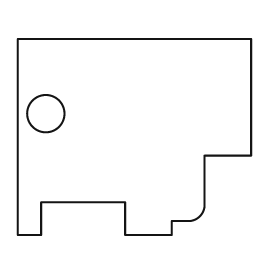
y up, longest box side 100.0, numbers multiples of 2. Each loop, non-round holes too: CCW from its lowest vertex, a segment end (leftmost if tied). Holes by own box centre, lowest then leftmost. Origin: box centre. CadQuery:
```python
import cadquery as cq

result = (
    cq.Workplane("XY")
    .moveTo(-50.0, -42.0)
    .lineTo(-40.0, -42.0)
    .lineTo(-40.0, -28.0)
    .lineTo(-4.0, -28.0)
    .lineTo(-4.0, -42.0)
    .lineTo(16.0, -42.0)
    .lineTo(16.0, -36.0)
    .lineTo(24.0, -36.0)
    .threePointArc((28.0, -34.0), (30.0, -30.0))
    .lineTo(30.0, -8.0)
    .lineTo(50.0, -8.0)
    .lineTo(50.0, 42.0)
    .lineTo(-50.0, 42.0)
    .close()
    .moveTo(-38.0, 10.0)
    .circle(8.0)
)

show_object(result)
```